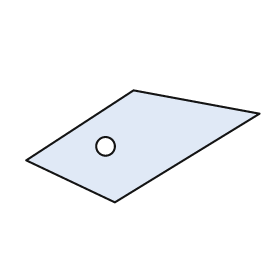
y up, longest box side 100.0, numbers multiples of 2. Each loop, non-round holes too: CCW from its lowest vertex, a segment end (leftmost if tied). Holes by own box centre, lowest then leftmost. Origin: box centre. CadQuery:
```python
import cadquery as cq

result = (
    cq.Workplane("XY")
    .moveTo(-12.0, -24.0)
    .lineTo(50.0, 14.0)
    .lineTo(-4.0, 24.0)
    .lineTo(-50.0, -6.0)
    .close()
    .moveTo(-16.0, 0.0)
    .circle(4.0)
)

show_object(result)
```